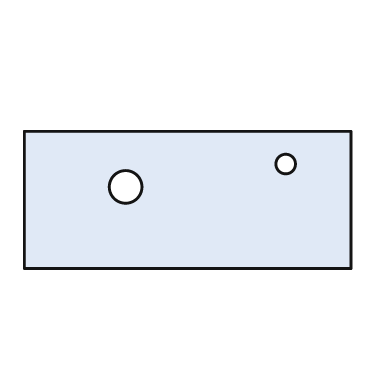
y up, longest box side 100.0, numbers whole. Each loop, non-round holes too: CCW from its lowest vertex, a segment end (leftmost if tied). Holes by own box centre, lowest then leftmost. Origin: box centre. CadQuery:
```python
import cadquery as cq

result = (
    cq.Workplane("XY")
    .moveTo(-50.0, -21.0)
    .lineTo(50.0, -21.0)
    .lineTo(50.0, 21.0)
    .lineTo(-50.0, 21.0)
    .close()
    .moveTo(-19.0, 4.0)
    .circle(5.0)
    .moveTo(30.0, 11.0)
    .circle(3.0)
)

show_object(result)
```